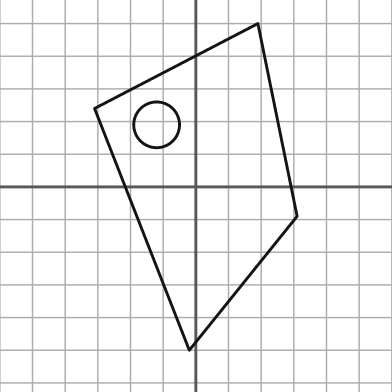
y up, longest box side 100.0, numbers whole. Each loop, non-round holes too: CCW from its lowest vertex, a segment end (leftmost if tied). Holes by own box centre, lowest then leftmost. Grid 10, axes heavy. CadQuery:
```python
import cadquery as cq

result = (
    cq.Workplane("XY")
    .moveTo(-2.0, -50.0)
    .lineTo(31.0, -9.0)
    .lineTo(19.0, 50.0)
    .lineTo(-31.0, 24.0)
    .close()
    .moveTo(-12.0, 19.0)
    .circle(7.0)
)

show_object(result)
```